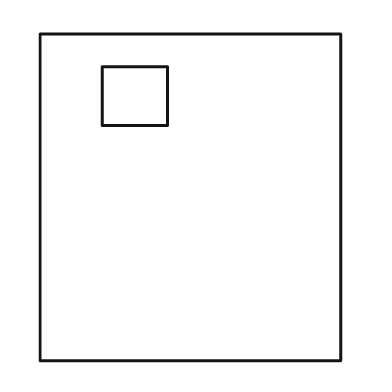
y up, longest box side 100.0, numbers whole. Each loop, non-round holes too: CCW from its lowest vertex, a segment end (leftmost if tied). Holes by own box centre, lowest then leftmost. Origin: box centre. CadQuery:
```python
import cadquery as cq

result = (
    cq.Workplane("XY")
    .moveTo(-46.0, -50.0)
    .lineTo(46.0, -50.0)
    .lineTo(46.0, 50.0)
    .lineTo(-46.0, 50.0)
    .close()
    .moveTo(-27.0, 22.0)
    .lineTo(-7.0, 22.0)
    .lineTo(-7.0, 40.0)
    .lineTo(-27.0, 40.0)
    .close()
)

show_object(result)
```